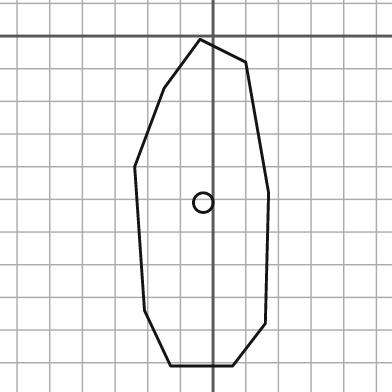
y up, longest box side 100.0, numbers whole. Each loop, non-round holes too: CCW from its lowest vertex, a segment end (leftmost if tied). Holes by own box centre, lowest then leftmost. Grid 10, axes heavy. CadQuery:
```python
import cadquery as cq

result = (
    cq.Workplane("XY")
    .moveTo(-13.0, -101.0)
    .lineTo(6.0, -101.0)
    .lineTo(16.0, -88.0)
    .lineTo(17.0, -48.0)
    .lineTo(10.0, -8.0)
    .lineTo(-4.0, -1.0)
    .lineTo(-15.0, -16.0)
    .lineTo(-24.0, -40.0)
    .lineTo(-21.0, -84.0)
    .close()
    .moveTo(-3.0, -51.0)
    .circle(3.0)
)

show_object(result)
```